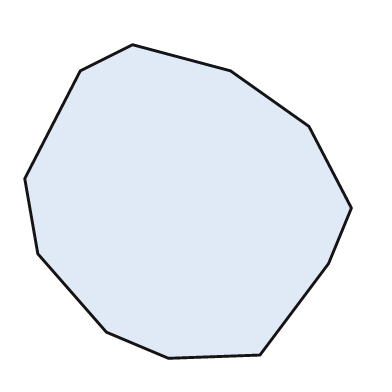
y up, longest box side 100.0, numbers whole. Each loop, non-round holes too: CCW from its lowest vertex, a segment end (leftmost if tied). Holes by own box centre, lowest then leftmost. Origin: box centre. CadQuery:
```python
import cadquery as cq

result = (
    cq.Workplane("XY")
    .moveTo(-6.0, -48.0)
    .lineTo(22.0, -47.0)
    .lineTo(43.0, -19.0)
    .lineTo(50.0, -2.0)
    .lineTo(37.0, 23.0)
    .lineTo(13.0, 40.0)
    .lineTo(-17.0, 48.0)
    .lineTo(-33.0, 40.0)
    .lineTo(-50.0, 7.0)
    .lineTo(-46.0, -16.0)
    .lineTo(-25.0, -40.0)
    .close()
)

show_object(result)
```